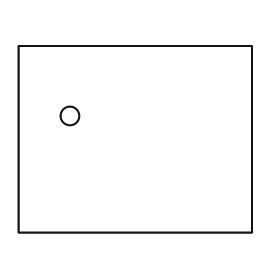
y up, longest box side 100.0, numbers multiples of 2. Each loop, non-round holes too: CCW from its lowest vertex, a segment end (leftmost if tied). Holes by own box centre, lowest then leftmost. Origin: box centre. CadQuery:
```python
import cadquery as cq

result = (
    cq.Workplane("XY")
    .moveTo(-50.0, -40.0)
    .lineTo(50.0, -40.0)
    .lineTo(50.0, 40.0)
    .lineTo(-50.0, 40.0)
    .close()
    .moveTo(-28.0, 10.0)
    .circle(4.0)
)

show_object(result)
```